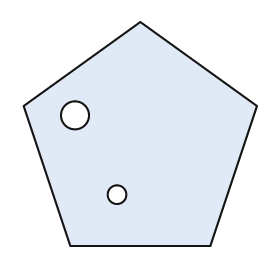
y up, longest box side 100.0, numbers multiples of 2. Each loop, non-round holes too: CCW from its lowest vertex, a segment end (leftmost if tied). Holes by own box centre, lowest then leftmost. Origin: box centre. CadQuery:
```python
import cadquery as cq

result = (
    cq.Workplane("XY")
    .moveTo(-30.0, -48.0)
    .lineTo(30.0, -48.0)
    .lineTo(50.0, 12.0)
    .lineTo(0.0, 48.0)
    .lineTo(-50.0, 12.0)
    .close()
    .moveTo(-10.0, -26.0)
    .circle(4.0)
    .moveTo(-28.0, 8.0)
    .circle(6.0)
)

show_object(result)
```